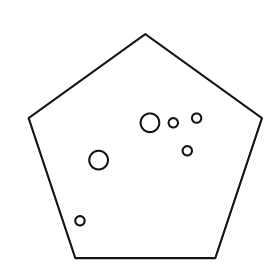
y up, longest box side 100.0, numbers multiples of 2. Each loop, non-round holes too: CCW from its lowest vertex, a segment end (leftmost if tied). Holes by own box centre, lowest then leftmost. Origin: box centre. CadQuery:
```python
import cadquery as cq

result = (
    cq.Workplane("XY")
    .moveTo(-30.0, -48.0)
    .lineTo(30.0, -48.0)
    .lineTo(50.0, 12.0)
    .lineTo(0.0, 48.0)
    .lineTo(-50.0, 12.0)
    .close()
    .moveTo(-28.0, -32.0)
    .circle(2.0)
    .moveTo(-20.0, -6.0)
    .circle(4.0)
    .moveTo(18.0, -2.0)
    .circle(2.0)
    .moveTo(2.0, 10.0)
    .circle(4.0)
    .moveTo(12.0, 10.0)
    .circle(2.0)
    .moveTo(22.0, 12.0)
    .circle(2.0)
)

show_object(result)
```